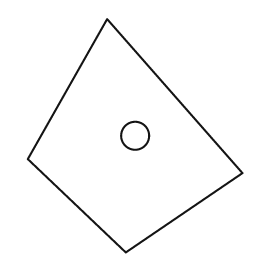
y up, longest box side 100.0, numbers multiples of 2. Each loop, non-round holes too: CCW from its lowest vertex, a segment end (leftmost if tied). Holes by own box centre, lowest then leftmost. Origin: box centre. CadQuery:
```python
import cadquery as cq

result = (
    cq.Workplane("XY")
    .moveTo(-4.0, -50.0)
    .lineTo(46.0, -16.0)
    .lineTo(-12.0, 50.0)
    .lineTo(-46.0, -10.0)
    .close()
    .moveTo(0.0, 0.0)
    .circle(6.0)
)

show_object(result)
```